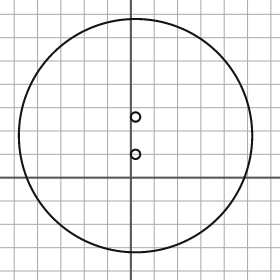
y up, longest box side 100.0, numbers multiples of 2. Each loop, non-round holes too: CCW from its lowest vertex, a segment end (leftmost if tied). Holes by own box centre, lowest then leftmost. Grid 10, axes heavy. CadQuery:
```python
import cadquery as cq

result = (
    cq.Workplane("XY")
    .moveTo(2.0, 18.0)
    .circle(50.0)
    .moveTo(2.0, 10.0)
    .circle(2.0)
    .moveTo(2.0, 26.0)
    .circle(2.0)
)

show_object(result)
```